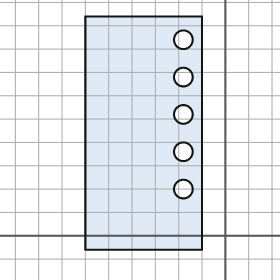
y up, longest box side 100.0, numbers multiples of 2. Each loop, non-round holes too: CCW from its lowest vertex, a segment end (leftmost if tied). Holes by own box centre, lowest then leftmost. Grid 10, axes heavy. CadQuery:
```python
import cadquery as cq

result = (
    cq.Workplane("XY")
    .moveTo(-60.0, -6.0)
    .lineTo(-10.0, -6.0)
    .lineTo(-10.0, 94.0)
    .lineTo(-60.0, 94.0)
    .close()
    .moveTo(-18.0, 20.0)
    .circle(4.0)
    .moveTo(-18.0, 36.0)
    .circle(4.0)
    .moveTo(-18.0, 52.0)
    .circle(4.0)
    .moveTo(-18.0, 68.0)
    .circle(4.0)
    .moveTo(-18.0, 84.0)
    .circle(4.0)
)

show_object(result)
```